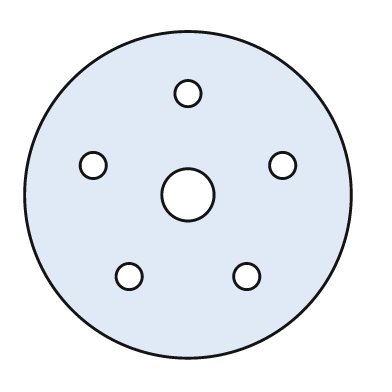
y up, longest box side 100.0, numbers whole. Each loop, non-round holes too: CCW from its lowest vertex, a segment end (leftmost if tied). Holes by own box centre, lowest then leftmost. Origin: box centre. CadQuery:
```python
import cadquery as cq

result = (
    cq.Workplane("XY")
    .moveTo(0.0, 0.0)
    .circle(50.0)
    .moveTo(-18.0, -25.0)
    .circle(4.0)
    .moveTo(18.0, -25.0)
    .circle(4.0)
    .moveTo(0.0, 0.0)
    .circle(8.0)
    .moveTo(-29.0, 9.0)
    .circle(4.0)
    .moveTo(29.0, 9.0)
    .circle(4.0)
    .moveTo(0.0, 31.0)
    .circle(4.0)
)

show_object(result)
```